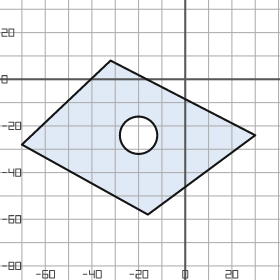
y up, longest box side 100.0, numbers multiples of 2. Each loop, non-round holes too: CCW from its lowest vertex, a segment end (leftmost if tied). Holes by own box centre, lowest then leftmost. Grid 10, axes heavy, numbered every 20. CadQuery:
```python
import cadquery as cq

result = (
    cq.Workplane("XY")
    .moveTo(-16.0, -58.0)
    .lineTo(30.0, -24.0)
    .lineTo(-32.0, 8.0)
    .lineTo(-70.0, -28.0)
    .close()
    .moveTo(-20.0, -24.0)
    .circle(8.0)
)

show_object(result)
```